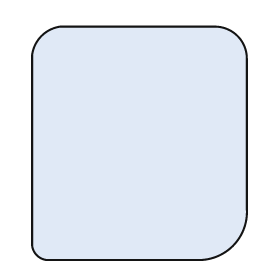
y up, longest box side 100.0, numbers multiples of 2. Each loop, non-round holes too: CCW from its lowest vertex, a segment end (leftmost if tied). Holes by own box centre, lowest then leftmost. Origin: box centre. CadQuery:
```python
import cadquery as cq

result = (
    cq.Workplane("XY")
    .moveTo(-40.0, -50.0)
    .lineTo(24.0, -50.0)
    .threePointArc((40.0, -44.0), (46.0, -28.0))
    .lineTo(46.0, 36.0)
    .threePointArc((42.0, 46.0), (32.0, 50.0))
    .lineTo(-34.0, 50.0)
    .threePointArc((-42.0, 46.0), (-46.0, 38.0))
    .lineTo(-46.0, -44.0)
    .threePointArc((-44.0, -48.0), (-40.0, -50.0))
    .close()
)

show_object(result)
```